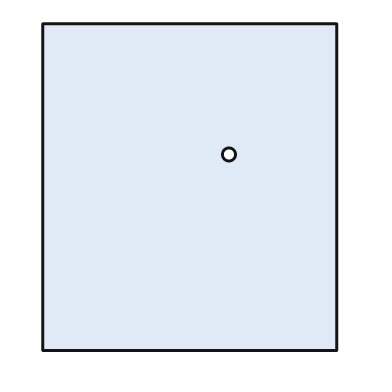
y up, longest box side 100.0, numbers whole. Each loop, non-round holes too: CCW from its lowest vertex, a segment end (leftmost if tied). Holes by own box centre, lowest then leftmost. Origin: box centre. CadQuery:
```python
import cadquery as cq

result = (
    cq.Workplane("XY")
    .moveTo(-45.0, -50.0)
    .lineTo(45.0, -50.0)
    .lineTo(45.0, 50.0)
    .lineTo(-45.0, 50.0)
    .close()
    .moveTo(12.0, 10.0)
    .circle(2.0)
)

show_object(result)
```